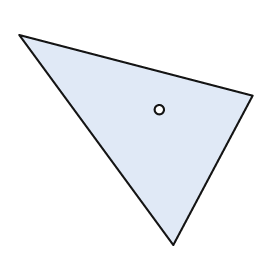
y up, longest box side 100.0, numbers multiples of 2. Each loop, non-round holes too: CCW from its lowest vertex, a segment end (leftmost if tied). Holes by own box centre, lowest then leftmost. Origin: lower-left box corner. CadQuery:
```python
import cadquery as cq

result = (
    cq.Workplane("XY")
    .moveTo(66.0, 0.0)
    .lineTo(100.0, 64.0)
    .lineTo(0.0, 90.0)
    .close()
    .moveTo(60.0, 58.0)
    .circle(2.0)
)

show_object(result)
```